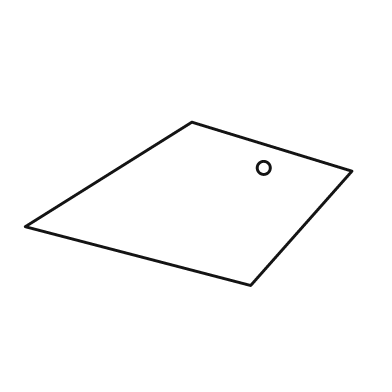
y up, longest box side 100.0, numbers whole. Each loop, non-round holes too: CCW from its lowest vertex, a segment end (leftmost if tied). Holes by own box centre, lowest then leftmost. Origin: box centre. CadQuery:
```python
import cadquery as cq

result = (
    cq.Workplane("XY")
    .moveTo(19.0, -25.0)
    .lineTo(50.0, 10.0)
    .lineTo(1.0, 25.0)
    .lineTo(-50.0, -7.0)
    .close()
    .moveTo(23.0, 11.0)
    .circle(2.0)
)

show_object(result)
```